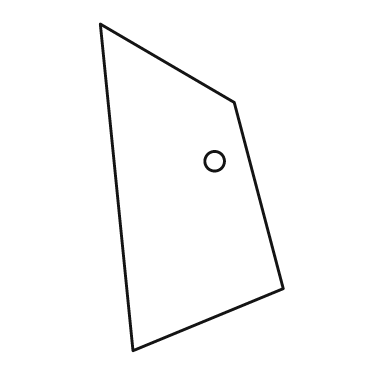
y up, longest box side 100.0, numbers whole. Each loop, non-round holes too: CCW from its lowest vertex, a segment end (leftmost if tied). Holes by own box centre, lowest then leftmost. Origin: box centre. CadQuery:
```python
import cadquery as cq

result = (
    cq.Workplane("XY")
    .moveTo(-18.0, -50.0)
    .lineTo(28.0, -31.0)
    .lineTo(13.0, 26.0)
    .lineTo(-28.0, 50.0)
    .close()
    .moveTo(7.0, 8.0)
    .circle(3.0)
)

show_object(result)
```